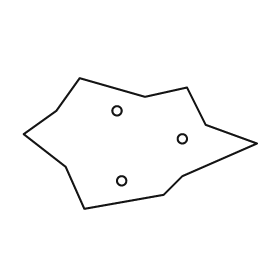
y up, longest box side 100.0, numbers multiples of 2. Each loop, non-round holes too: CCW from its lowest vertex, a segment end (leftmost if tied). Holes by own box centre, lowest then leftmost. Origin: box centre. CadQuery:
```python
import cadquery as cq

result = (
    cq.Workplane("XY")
    .moveTo(-24.0, -28.0)
    .lineTo(10.0, -22.0)
    .lineTo(18.0, -14.0)
    .lineTo(50.0, 0.0)
    .lineTo(28.0, 8.0)
    .lineTo(20.0, 24.0)
    .lineTo(2.0, 20.0)
    .lineTo(-26.0, 28.0)
    .lineTo(-36.0, 14.0)
    .lineTo(-50.0, 4.0)
    .lineTo(-32.0, -10.0)
    .close()
    .moveTo(-8.0, -16.0)
    .circle(2.0)
    .moveTo(18.0, 2.0)
    .circle(2.0)
    .moveTo(-10.0, 14.0)
    .circle(2.0)
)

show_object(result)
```